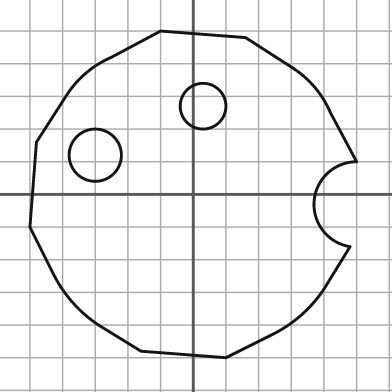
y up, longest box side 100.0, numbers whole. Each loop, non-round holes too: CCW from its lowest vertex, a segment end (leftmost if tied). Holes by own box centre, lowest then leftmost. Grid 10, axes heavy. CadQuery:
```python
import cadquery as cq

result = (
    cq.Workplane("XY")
    .moveTo(10.0, -50.0)
    .lineTo(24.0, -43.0)
    .threePointArc((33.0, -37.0), (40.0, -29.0))
    .lineTo(48.0, -16.0)
    .threePointArc((37.0, -2.0), (50.0, 10.0))
    .lineTo(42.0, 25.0)
    .threePointArc((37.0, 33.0), (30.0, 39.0))
    .lineTo(16.0, 48.0)
    .lineTo(-10.0, 50.0)
    .lineTo(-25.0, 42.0)
    .threePointArc((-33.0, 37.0), (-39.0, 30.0))
    .lineTo(-48.0, 16.0)
    .lineTo(-50.0, -10.0)
    .lineTo(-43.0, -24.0)
    .threePointArc((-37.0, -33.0), (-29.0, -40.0))
    .lineTo(-16.0, -48.0)
    .close()
    .moveTo(-30.0, 12.0)
    .circle(8.0)
    .moveTo(3.0, 27.0)
    .circle(7.0)
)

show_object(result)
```